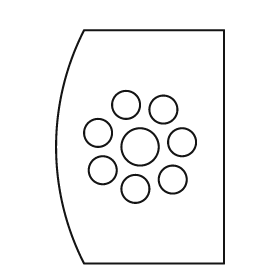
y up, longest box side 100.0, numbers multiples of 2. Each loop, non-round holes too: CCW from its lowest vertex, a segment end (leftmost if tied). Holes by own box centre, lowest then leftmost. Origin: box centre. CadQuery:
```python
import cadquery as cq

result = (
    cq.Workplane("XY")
    .moveTo(-24.0, -50.0)
    .lineTo(36.0, -50.0)
    .lineTo(36.0, 50.0)
    .lineTo(-24.0, 50.0)
    .threePointArc((-36.0, 0.0), (-24.0, -50.0))
    .close()
    .moveTo(-2.0, -18.0)
    .circle(6.0)
    .moveTo(14.0, -14.0)
    .circle(6.0)
    .moveTo(-16.0, -10.0)
    .circle(6.0)
    .moveTo(0.0, 0.0)
    .circle(8.0)
    .moveTo(18.0, 2.0)
    .circle(6.0)
    .moveTo(-18.0, 6.0)
    .circle(6.0)
    .moveTo(10.0, 16.0)
    .circle(6.0)
    .moveTo(-6.0, 18.0)
    .circle(6.0)
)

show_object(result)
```